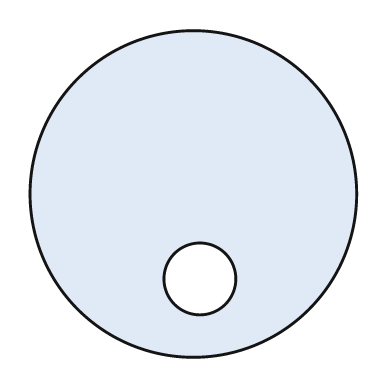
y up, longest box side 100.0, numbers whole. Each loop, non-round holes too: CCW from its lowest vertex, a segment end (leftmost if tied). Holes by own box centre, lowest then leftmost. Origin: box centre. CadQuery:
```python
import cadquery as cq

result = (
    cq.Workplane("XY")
    .moveTo(0.0, 0.0)
    .circle(50.0)
    .moveTo(2.0, -26.0)
    .circle(11.0)
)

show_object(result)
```